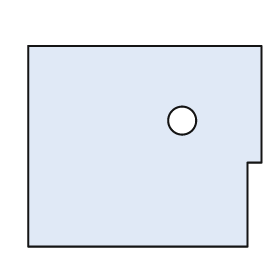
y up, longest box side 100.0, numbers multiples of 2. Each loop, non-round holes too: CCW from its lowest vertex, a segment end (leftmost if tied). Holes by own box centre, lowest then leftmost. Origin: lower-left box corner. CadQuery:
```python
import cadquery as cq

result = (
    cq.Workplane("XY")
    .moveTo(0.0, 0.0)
    .lineTo(94.0, 0.0)
    .lineTo(94.0, 36.0)
    .lineTo(100.0, 36.0)
    .lineTo(100.0, 86.0)
    .lineTo(0.0, 86.0)
    .close()
    .moveTo(66.0, 54.0)
    .circle(6.0)
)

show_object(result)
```